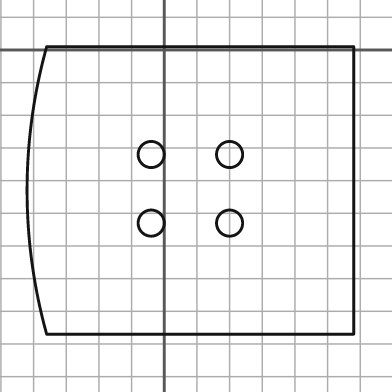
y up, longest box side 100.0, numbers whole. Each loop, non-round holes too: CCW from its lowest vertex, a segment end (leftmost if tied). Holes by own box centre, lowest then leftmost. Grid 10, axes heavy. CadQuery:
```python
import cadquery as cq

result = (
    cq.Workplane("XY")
    .moveTo(-36.0, -87.0)
    .lineTo(58.0, -87.0)
    .lineTo(58.0, 1.0)
    .lineTo(-36.0, 1.0)
    .threePointArc((-42.0, -43.0), (-36.0, -87.0))
    .close()
    .moveTo(-4.0, -53.0)
    .circle(4.0)
    .moveTo(20.0, -53.0)
    .circle(4.0)
    .moveTo(-4.0, -32.0)
    .circle(4.0)
    .moveTo(20.0, -32.0)
    .circle(4.0)
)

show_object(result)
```